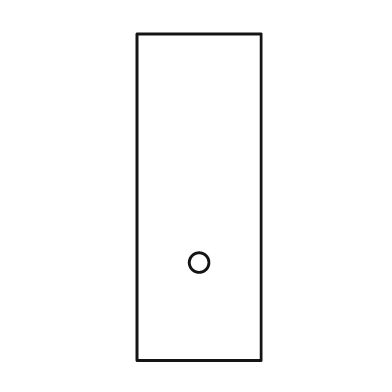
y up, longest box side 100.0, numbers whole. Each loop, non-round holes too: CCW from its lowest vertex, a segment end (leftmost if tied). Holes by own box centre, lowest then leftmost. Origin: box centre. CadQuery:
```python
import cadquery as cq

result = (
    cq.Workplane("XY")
    .moveTo(-19.0, -50.0)
    .lineTo(19.0, -50.0)
    .lineTo(19.0, 50.0)
    .lineTo(-19.0, 50.0)
    .close()
    .moveTo(0.0, -20.0)
    .circle(3.0)
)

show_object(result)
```